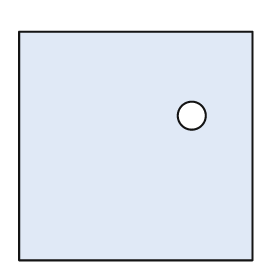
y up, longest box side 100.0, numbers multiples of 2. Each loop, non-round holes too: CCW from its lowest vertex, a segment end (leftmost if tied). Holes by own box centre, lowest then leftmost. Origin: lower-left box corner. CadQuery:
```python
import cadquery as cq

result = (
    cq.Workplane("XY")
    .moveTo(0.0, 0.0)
    .lineTo(100.0, 0.0)
    .lineTo(100.0, 98.0)
    .lineTo(0.0, 98.0)
    .close()
    .moveTo(74.0, 62.0)
    .circle(6.0)
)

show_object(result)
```